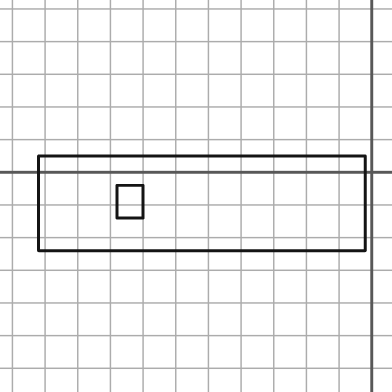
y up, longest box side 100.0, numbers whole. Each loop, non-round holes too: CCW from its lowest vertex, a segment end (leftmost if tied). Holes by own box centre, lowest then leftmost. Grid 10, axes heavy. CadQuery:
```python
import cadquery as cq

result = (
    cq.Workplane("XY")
    .moveTo(-102.0, -24.0)
    .lineTo(-2.0, -24.0)
    .lineTo(-2.0, 5.0)
    .lineTo(-102.0, 5.0)
    .close()
    .moveTo(-78.0, -14.0)
    .lineTo(-70.0, -14.0)
    .lineTo(-70.0, -4.0)
    .lineTo(-78.0, -4.0)
    .close()
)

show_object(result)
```